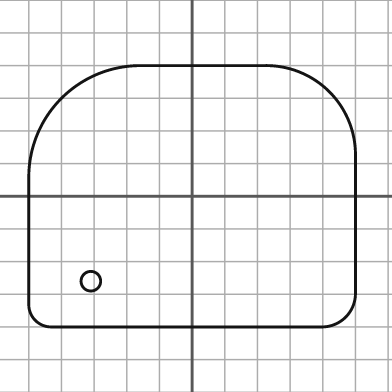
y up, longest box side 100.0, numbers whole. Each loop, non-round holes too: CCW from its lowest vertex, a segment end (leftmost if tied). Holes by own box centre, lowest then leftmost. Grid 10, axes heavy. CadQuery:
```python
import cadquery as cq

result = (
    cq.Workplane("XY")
    .moveTo(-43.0, -40.0)
    .lineTo(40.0, -40.0)
    .threePointArc((47.0, -37.0), (50.0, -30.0))
    .lineTo(50.0, 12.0)
    .threePointArc((42.0, 32.0), (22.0, 40.0))
    .lineTo(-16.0, 40.0)
    .threePointArc((-40.0, 30.0), (-50.0, 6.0))
    .lineTo(-50.0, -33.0)
    .threePointArc((-48.0, -38.0), (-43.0, -40.0))
    .close()
    .moveTo(-31.0, -26.0)
    .circle(3.0)
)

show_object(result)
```